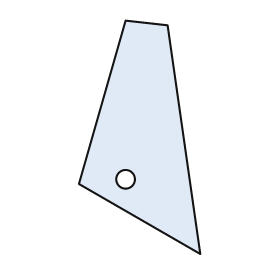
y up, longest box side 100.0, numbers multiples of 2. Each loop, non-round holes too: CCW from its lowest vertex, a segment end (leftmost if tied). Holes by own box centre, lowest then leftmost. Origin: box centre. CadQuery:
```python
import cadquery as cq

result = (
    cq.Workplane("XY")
    .moveTo(26.0, -50.0)
    .lineTo(12.0, 48.0)
    .lineTo(-6.0, 50.0)
    .lineTo(-26.0, -20.0)
    .close()
    .moveTo(-6.0, -18.0)
    .circle(4.0)
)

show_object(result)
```